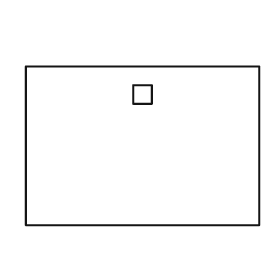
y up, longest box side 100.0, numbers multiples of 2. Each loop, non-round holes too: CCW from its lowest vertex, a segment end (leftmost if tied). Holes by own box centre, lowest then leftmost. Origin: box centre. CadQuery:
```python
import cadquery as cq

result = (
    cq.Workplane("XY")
    .moveTo(-50.0, -34.0)
    .lineTo(50.0, -34.0)
    .lineTo(50.0, 34.0)
    .lineTo(-50.0, 34.0)
    .close()
    .moveTo(-4.0, 18.0)
    .lineTo(4.0, 18.0)
    .lineTo(4.0, 26.0)
    .lineTo(-4.0, 26.0)
    .close()
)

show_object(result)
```